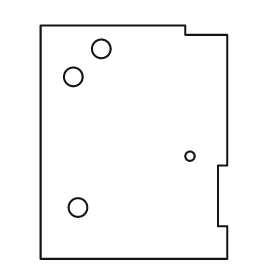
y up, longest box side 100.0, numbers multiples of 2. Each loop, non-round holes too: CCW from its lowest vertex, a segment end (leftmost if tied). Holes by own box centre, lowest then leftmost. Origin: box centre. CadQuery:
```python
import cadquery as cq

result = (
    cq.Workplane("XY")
    .moveTo(-40.0, -50.0)
    .lineTo(40.0, -50.0)
    .lineTo(40.0, -36.0)
    .lineTo(36.0, -36.0)
    .lineTo(36.0, -10.0)
    .lineTo(40.0, -10.0)
    .lineTo(40.0, 46.0)
    .lineTo(22.0, 46.0)
    .lineTo(22.0, 50.0)
    .lineTo(-40.0, 50.0)
    .close()
    .moveTo(-24.0, -28.0)
    .circle(4.0)
    .moveTo(24.0, -6.0)
    .circle(2.0)
    .moveTo(-26.0, 28.0)
    .circle(4.0)
    .moveTo(-14.0, 40.0)
    .circle(4.0)
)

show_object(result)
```